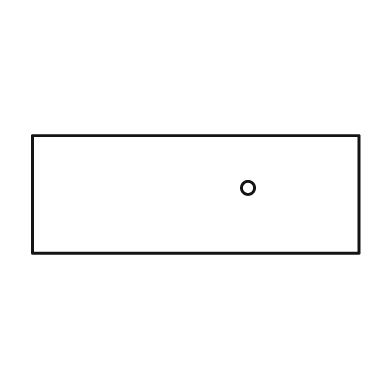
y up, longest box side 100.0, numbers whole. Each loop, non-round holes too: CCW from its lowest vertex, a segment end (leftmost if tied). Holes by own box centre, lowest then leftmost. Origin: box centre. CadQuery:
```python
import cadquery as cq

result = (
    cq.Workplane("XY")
    .moveTo(-50.0, -18.0)
    .lineTo(50.0, -18.0)
    .lineTo(50.0, 18.0)
    .lineTo(-50.0, 18.0)
    .close()
    .moveTo(16.0, 2.0)
    .circle(2.0)
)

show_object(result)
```